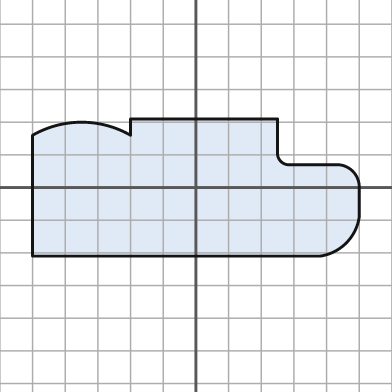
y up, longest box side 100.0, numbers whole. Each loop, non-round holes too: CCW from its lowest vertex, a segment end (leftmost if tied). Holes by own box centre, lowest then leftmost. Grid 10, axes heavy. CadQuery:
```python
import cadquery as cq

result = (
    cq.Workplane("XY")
    .moveTo(-50.0, -21.0)
    .lineTo(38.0, -21.0)
    .threePointArc((46.0, -17.0), (50.0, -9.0))
    .lineTo(50.0, 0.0)
    .threePointArc((48.0, 5.0), (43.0, 7.0))
    .lineTo(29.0, 7.0)
    .threePointArc((26.0, 8.0), (25.0, 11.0))
    .lineTo(25.0, 21.0)
    .lineTo(-20.0, 21.0)
    .lineTo(-20.0, 16.0)
    .threePointArc((-35.0, 20.0), (-50.0, 16.0))
    .close()
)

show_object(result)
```